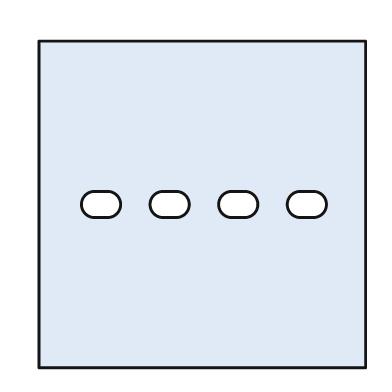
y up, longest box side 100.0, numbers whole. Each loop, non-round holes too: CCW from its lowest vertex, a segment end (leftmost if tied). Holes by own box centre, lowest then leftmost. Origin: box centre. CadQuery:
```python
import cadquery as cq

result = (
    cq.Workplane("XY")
    .moveTo(-50.0, -50.0)
    .lineTo(50.0, -50.0)
    .lineTo(50.0, 50.0)
    .lineTo(-50.0, 50.0)
    .close()
    .moveTo(-33.0, -4.0)
    .lineTo(-29.0, -4.0)
    .threePointArc((-25.0, 0.0), (-29.0, 4.0))
    .lineTo(-33.0, 4.0)
    .threePointArc((-37.0, 0.0), (-33.0, -4.0))
    .close()
    .moveTo(-12.0, -4.0)
    .lineTo(-8.0, -4.0)
    .threePointArc((-4.0, 0.0), (-8.0, 4.0))
    .lineTo(-12.0, 4.0)
    .threePointArc((-16.0, 0.0), (-12.0, -4.0))
    .close()
    .moveTo(9.0, -4.0)
    .lineTo(13.0, -4.0)
    .threePointArc((17.0, 0.0), (13.0, 4.0))
    .lineTo(9.0, 4.0)
    .threePointArc((5.0, 0.0), (9.0, -4.0))
    .close()
    .moveTo(30.0, -4.0)
    .lineTo(34.0, -4.0)
    .threePointArc((38.0, 0.0), (34.0, 4.0))
    .lineTo(30.0, 4.0)
    .threePointArc((26.0, 0.0), (30.0, -4.0))
    .close()
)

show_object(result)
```